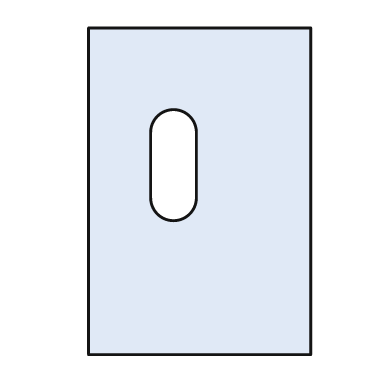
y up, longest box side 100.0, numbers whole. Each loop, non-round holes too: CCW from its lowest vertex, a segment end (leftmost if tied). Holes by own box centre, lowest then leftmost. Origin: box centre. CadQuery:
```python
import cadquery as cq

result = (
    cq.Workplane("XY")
    .moveTo(-34.0, -50.0)
    .lineTo(34.0, -50.0)
    .lineTo(34.0, 50.0)
    .lineTo(-34.0, 50.0)
    .close()
    .moveTo(-15.0, -2.0)
    .threePointArc((-8.0, -9.0), (-1.0, -2.0))
    .lineTo(-1.0, 18.0)
    .threePointArc((-8.0, 25.0), (-15.0, 18.0))
    .close()
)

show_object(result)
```